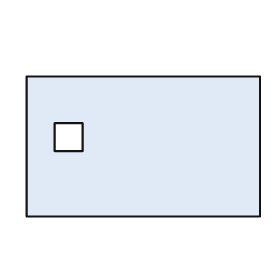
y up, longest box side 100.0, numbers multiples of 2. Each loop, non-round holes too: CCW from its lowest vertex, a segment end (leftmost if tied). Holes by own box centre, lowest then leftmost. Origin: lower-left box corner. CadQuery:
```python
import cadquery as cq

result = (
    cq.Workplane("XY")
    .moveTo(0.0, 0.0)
    .lineTo(100.0, 0.0)
    .lineTo(100.0, 60.0)
    .lineTo(0.0, 60.0)
    .close()
    .moveTo(12.0, 28.0)
    .lineTo(24.0, 28.0)
    .lineTo(24.0, 40.0)
    .lineTo(12.0, 40.0)
    .close()
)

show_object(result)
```